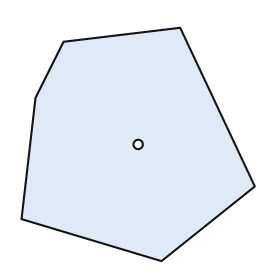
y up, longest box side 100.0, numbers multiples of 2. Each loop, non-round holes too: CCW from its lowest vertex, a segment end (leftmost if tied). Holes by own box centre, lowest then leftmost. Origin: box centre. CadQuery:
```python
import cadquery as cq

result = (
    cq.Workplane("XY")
    .moveTo(10.0, -50.0)
    .lineTo(50.0, -18.0)
    .lineTo(18.0, 50.0)
    .lineTo(-32.0, 44.0)
    .lineTo(-44.0, 20.0)
    .lineTo(-50.0, -32.0)
    .close()
    .moveTo(0.0, 0.0)
    .circle(2.0)
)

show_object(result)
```